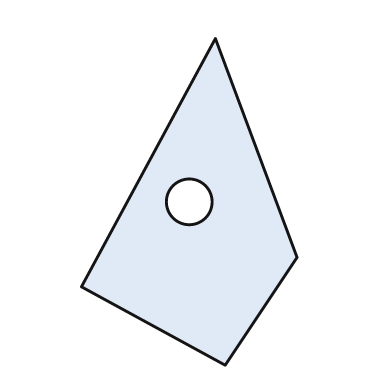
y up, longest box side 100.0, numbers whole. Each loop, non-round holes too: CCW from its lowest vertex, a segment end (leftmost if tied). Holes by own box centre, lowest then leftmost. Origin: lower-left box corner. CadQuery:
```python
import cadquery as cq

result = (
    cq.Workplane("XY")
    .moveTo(44.0, 0.0)
    .lineTo(66.0, 33.0)
    .lineTo(41.0, 100.0)
    .lineTo(0.0, 24.0)
    .close()
    .moveTo(33.0, 50.0)
    .circle(7.0)
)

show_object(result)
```